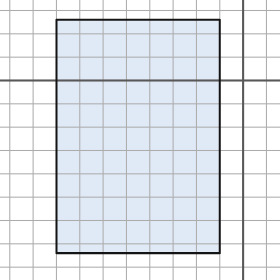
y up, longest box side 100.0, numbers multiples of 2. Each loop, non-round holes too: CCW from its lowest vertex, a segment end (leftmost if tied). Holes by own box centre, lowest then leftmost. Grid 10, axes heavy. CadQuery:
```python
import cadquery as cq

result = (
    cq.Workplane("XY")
    .moveTo(-80.0, -74.0)
    .lineTo(-10.0, -74.0)
    .lineTo(-10.0, 26.0)
    .lineTo(-80.0, 26.0)
    .close()
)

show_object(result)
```